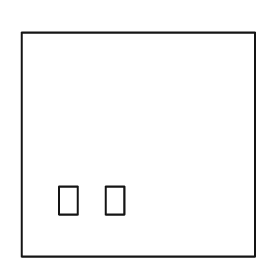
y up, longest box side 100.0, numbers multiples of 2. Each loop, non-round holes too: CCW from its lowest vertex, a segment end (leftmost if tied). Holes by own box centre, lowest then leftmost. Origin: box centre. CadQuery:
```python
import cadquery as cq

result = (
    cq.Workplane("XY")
    .moveTo(-50.0, -48.0)
    .lineTo(50.0, -48.0)
    .lineTo(50.0, 48.0)
    .lineTo(-50.0, 48.0)
    .close()
    .moveTo(-34.0, -30.0)
    .lineTo(-26.0, -30.0)
    .lineTo(-26.0, -18.0)
    .lineTo(-34.0, -18.0)
    .close()
    .moveTo(-14.0, -30.0)
    .lineTo(-6.0, -30.0)
    .lineTo(-6.0, -18.0)
    .lineTo(-14.0, -18.0)
    .close()
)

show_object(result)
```